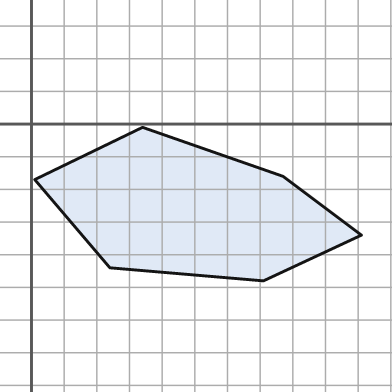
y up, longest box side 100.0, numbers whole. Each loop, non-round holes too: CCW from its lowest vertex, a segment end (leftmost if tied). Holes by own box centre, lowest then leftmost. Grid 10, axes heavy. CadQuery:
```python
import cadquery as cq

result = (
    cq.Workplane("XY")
    .moveTo(71.0, -48.0)
    .lineTo(101.0, -34.0)
    .lineTo(77.0, -16.0)
    .lineTo(34.0, -1.0)
    .lineTo(1.0, -17.0)
    .lineTo(24.0, -44.0)
    .close()
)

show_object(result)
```